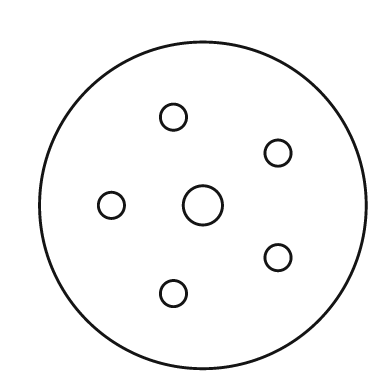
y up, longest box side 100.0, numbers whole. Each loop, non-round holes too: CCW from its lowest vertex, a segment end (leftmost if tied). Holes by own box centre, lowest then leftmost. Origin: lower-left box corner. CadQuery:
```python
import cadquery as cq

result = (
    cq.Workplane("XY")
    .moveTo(50.0, 50.0)
    .circle(50.0)
    .moveTo(41.0, 23.0)
    .circle(4.0)
    .moveTo(73.0, 34.0)
    .circle(4.0)
    .moveTo(22.0, 50.0)
    .circle(4.0)
    .moveTo(50.0, 50.0)
    .circle(6.0)
    .moveTo(73.0, 66.0)
    .circle(4.0)
    .moveTo(41.0, 77.0)
    .circle(4.0)
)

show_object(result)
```